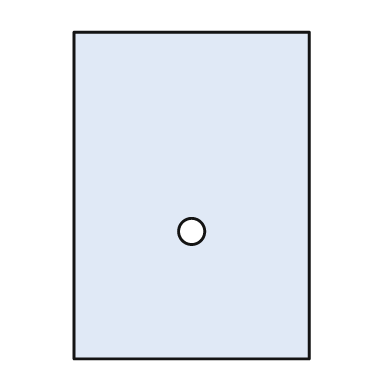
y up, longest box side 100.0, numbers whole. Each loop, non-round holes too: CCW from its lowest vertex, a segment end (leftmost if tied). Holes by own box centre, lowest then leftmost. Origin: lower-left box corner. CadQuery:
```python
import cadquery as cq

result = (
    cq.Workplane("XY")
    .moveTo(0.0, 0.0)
    .lineTo(72.0, 0.0)
    .lineTo(72.0, 100.0)
    .lineTo(0.0, 100.0)
    .close()
    .moveTo(36.0, 39.0)
    .circle(4.0)
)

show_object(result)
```